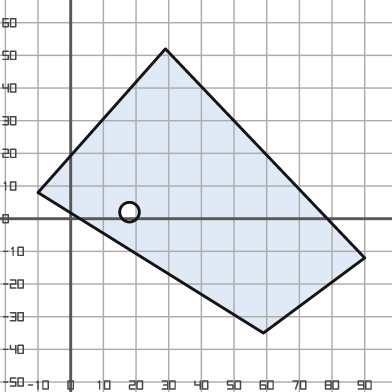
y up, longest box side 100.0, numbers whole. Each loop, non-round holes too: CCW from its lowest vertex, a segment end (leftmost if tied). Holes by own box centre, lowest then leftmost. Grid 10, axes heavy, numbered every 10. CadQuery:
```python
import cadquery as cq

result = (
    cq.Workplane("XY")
    .moveTo(59.0, -35.0)
    .lineTo(90.0, -12.0)
    .lineTo(29.0, 52.0)
    .lineTo(-10.0, 8.0)
    .close()
    .moveTo(18.0, 2.0)
    .circle(3.0)
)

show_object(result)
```